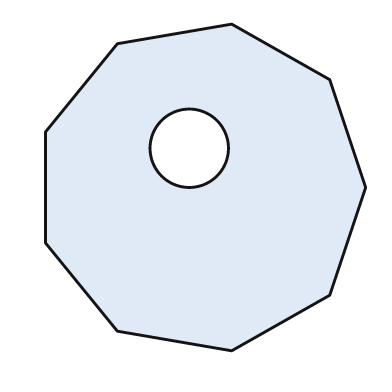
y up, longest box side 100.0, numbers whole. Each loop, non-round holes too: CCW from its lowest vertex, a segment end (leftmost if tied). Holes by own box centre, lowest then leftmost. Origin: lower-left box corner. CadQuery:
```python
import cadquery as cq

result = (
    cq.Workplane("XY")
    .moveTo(57.0, 0.0)
    .lineTo(87.0, 17.0)
    .lineTo(98.0, 50.0)
    .lineTo(87.0, 83.0)
    .lineTo(57.0, 100.0)
    .lineTo(22.0, 94.0)
    .lineTo(0.0, 67.0)
    .lineTo(0.0, 33.0)
    .lineTo(22.0, 6.0)
    .close()
    .moveTo(44.0, 62.0)
    .circle(12.0)
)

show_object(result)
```